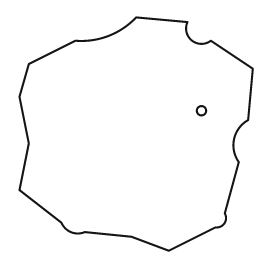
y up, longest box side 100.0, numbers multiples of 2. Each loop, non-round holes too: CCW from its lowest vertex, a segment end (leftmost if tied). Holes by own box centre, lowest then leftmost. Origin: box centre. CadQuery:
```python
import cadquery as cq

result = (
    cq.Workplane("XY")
    .moveTo(14.0, -50.0)
    .lineTo(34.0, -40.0)
    .threePointArc((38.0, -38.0), (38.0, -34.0))
    .lineTo(44.0, -12.0)
    .threePointArc((42.0, -2.0), (48.0, 6.0))
    .lineTo(50.0, 28.0)
    .lineTo(32.0, 40.0)
    .threePointArc((24.0, 40.0), (22.0, 48.0))
    .lineTo(0.0, 50.0)
    .threePointArc((-12.0, 42.0), (-26.0, 40.0))
    .lineTo(-46.0, 30.0)
    .lineTo(-50.0, 16.0)
    .lineTo(-46.0, -4.0)
    .lineTo(-50.0, -24.0)
    .lineTo(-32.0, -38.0)
    .threePointArc((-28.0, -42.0), (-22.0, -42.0))
    .lineTo(-2.0, -44.0)
    .close()
    .moveTo(28.0, 10.0)
    .circle(2.0)
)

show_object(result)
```